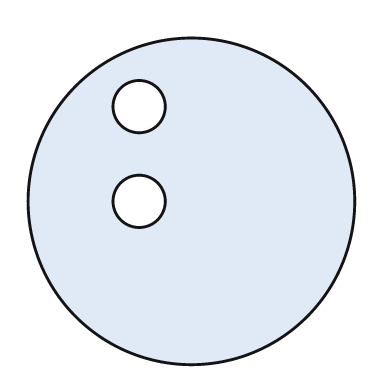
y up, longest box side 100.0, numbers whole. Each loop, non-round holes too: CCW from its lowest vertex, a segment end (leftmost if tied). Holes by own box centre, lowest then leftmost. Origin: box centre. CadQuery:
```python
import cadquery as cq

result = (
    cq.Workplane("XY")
    .moveTo(0.0, 0.0)
    .circle(50.0)
    .moveTo(-16.0, 0.0)
    .circle(8.0)
    .moveTo(-16.0, 29.0)
    .circle(8.0)
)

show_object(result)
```